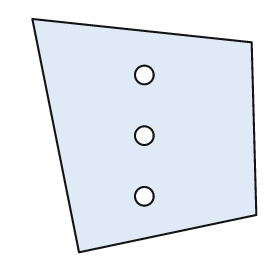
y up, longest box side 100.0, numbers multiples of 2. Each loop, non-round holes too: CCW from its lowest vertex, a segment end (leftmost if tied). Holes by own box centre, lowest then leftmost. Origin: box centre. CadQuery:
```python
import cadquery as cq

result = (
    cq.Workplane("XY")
    .moveTo(-28.0, -50.0)
    .lineTo(48.0, -34.0)
    .lineTo(46.0, 40.0)
    .lineTo(-48.0, 50.0)
    .close()
    .moveTo(0.0, -26.0)
    .circle(4.0)
    .moveTo(0.0, 0.0)
    .circle(4.0)
    .moveTo(0.0, 26.0)
    .circle(4.0)
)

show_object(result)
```